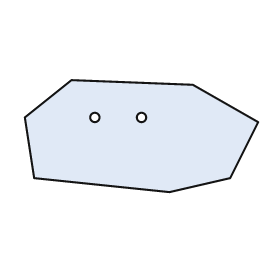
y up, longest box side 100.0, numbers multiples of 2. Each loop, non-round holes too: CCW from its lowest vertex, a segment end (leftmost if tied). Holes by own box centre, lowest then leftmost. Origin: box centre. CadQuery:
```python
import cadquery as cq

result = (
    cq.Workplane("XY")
    .moveTo(12.0, -24.0)
    .lineTo(38.0, -18.0)
    .lineTo(50.0, 6.0)
    .lineTo(22.0, 22.0)
    .lineTo(-30.0, 24.0)
    .lineTo(-50.0, 8.0)
    .lineTo(-46.0, -18.0)
    .close()
    .moveTo(-20.0, 8.0)
    .circle(2.0)
    .moveTo(0.0, 8.0)
    .circle(2.0)
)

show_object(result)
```